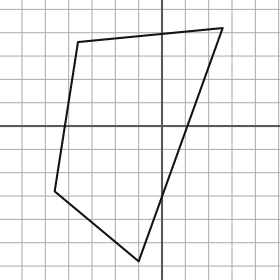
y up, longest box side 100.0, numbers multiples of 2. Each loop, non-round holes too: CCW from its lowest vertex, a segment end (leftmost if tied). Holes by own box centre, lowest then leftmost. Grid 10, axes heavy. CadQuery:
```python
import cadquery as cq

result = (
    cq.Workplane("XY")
    .moveTo(-10.0, -58.0)
    .lineTo(26.0, 42.0)
    .lineTo(-36.0, 36.0)
    .lineTo(-46.0, -28.0)
    .close()
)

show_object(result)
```